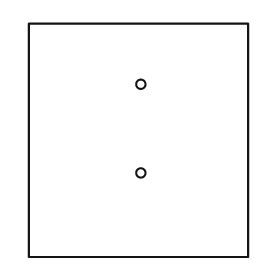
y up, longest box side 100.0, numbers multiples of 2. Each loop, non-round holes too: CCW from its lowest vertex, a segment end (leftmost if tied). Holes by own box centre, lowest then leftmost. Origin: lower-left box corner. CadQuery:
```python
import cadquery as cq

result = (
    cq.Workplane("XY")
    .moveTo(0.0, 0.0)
    .lineTo(94.0, 0.0)
    .lineTo(94.0, 100.0)
    .lineTo(0.0, 100.0)
    .close()
    .moveTo(48.0, 36.0)
    .circle(2.0)
    .moveTo(48.0, 74.0)
    .circle(2.0)
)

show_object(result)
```